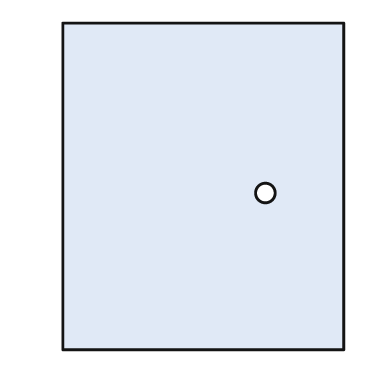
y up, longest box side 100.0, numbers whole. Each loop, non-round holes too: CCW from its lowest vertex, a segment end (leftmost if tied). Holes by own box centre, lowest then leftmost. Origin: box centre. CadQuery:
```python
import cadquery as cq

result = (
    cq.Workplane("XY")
    .moveTo(-43.0, -50.0)
    .lineTo(43.0, -50.0)
    .lineTo(43.0, 50.0)
    .lineTo(-43.0, 50.0)
    .close()
    .moveTo(19.0, -2.0)
    .circle(3.0)
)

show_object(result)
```